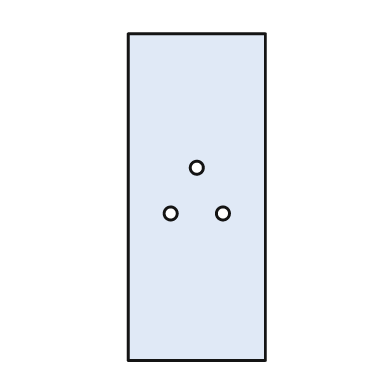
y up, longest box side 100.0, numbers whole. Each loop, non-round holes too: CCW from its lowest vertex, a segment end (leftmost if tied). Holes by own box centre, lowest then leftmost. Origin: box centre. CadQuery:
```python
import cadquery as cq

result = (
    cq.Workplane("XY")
    .moveTo(-21.0, -50.0)
    .lineTo(21.0, -50.0)
    .lineTo(21.0, 50.0)
    .lineTo(-21.0, 50.0)
    .close()
    .moveTo(-8.0, -5.0)
    .circle(2.0)
    .moveTo(8.0, -5.0)
    .circle(2.0)
    .moveTo(0.0, 9.0)
    .circle(2.0)
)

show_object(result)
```